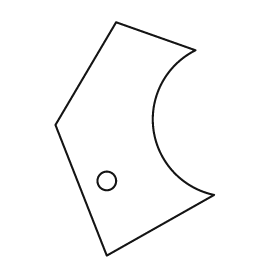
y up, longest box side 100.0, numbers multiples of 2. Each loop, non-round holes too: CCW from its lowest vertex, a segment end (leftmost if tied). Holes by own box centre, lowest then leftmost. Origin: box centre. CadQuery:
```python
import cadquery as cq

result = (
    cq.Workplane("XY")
    .moveTo(-12.0, -50.0)
    .lineTo(34.0, -24.0)
    .threePointArc((8.0, 4.0), (26.0, 38.0))
    .lineTo(-8.0, 50.0)
    .lineTo(-34.0, 6.0)
    .close()
    .moveTo(-12.0, -18.0)
    .circle(4.0)
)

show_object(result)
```